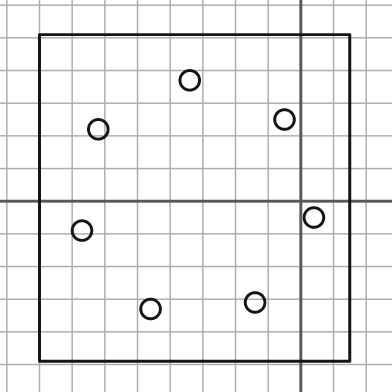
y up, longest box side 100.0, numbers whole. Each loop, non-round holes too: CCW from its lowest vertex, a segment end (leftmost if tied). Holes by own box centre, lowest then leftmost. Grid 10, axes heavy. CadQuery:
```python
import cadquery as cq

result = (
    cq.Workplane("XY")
    .moveTo(-80.0, -49.0)
    .lineTo(15.0, -49.0)
    .lineTo(15.0, 51.0)
    .lineTo(-80.0, 51.0)
    .close()
    .moveTo(-46.0, -33.0)
    .circle(3.0)
    .moveTo(-14.0, -31.0)
    .circle(3.0)
    .moveTo(-67.0, -9.0)
    .circle(3.0)
    .moveTo(4.0, -5.0)
    .circle(3.0)
    .moveTo(-62.0, 22.0)
    .circle(3.0)
    .moveTo(-5.0, 25.0)
    .circle(3.0)
    .moveTo(-34.0, 37.0)
    .circle(3.0)
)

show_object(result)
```